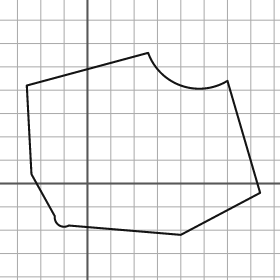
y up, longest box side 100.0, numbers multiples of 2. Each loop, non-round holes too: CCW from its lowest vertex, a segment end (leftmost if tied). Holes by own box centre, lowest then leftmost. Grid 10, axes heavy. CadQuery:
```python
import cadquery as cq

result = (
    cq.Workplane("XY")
    .moveTo(40.0, -22.0)
    .lineTo(74.0, -4.0)
    .lineTo(60.0, 44.0)
    .threePointArc((40.0, 42.0), (26.0, 56.0))
    .lineTo(-26.0, 42.0)
    .lineTo(-24.0, 4.0)
    .lineTo(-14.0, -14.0)
    .threePointArc((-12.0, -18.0), (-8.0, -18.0))
    .close()
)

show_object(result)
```